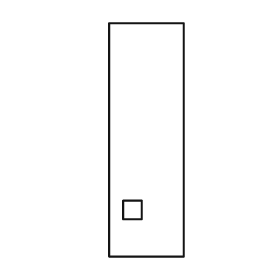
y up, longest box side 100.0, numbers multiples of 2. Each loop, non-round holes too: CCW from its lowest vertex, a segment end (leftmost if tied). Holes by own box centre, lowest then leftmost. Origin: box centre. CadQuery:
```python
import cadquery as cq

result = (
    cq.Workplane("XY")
    .moveTo(-16.0, -50.0)
    .lineTo(16.0, -50.0)
    .lineTo(16.0, 50.0)
    .lineTo(-16.0, 50.0)
    .close()
    .moveTo(-10.0, -34.0)
    .lineTo(-2.0, -34.0)
    .lineTo(-2.0, -26.0)
    .lineTo(-10.0, -26.0)
    .close()
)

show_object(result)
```